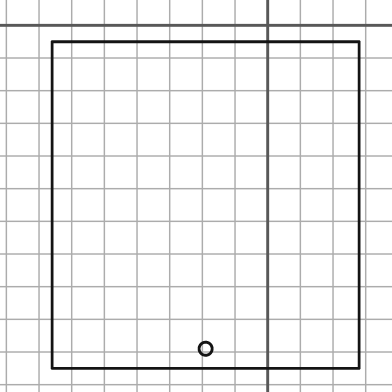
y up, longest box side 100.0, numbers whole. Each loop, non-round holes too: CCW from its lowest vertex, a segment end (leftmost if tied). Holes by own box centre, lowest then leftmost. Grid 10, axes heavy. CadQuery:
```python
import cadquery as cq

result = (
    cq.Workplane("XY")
    .moveTo(-66.0, -105.0)
    .lineTo(28.0, -105.0)
    .lineTo(28.0, -5.0)
    .lineTo(-66.0, -5.0)
    .close()
    .moveTo(-19.0, -99.0)
    .circle(2.0)
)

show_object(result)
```